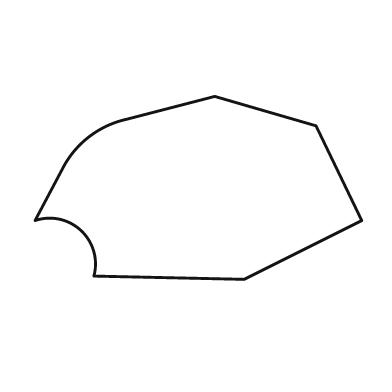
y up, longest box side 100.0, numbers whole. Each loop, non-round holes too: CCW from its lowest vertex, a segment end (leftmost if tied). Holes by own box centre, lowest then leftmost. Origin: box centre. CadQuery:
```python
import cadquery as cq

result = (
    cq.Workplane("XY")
    .moveTo(14.0, -28.0)
    .lineTo(50.0, -10.0)
    .lineTo(36.0, 19.0)
    .lineTo(5.0, 28.0)
    .lineTo(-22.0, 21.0)
    .threePointArc((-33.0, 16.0), (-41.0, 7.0))
    .lineTo(-50.0, -10.0)
    .threePointArc((-36.0, -13.0), (-32.0, -27.0))
    .close()
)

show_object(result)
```